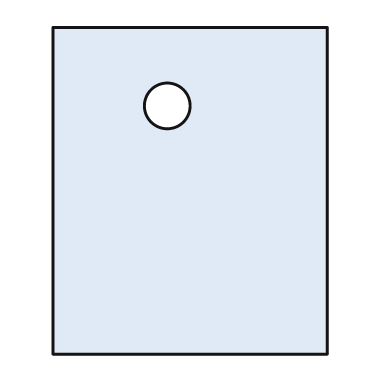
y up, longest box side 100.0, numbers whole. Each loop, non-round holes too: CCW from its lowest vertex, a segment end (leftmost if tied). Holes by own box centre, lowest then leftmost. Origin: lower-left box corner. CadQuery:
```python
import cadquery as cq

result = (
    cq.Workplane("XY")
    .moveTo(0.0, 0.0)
    .lineTo(84.0, 0.0)
    .lineTo(84.0, 100.0)
    .lineTo(0.0, 100.0)
    .close()
    .moveTo(35.0, 76.0)
    .circle(7.0)
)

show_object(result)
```